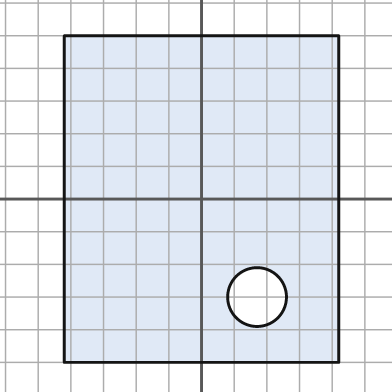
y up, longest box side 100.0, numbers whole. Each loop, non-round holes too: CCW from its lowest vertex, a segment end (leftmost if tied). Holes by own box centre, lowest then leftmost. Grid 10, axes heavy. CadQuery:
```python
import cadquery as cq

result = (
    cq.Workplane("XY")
    .moveTo(-42.0, -50.0)
    .lineTo(42.0, -50.0)
    .lineTo(42.0, 50.0)
    .lineTo(-42.0, 50.0)
    .close()
    .moveTo(17.0, -30.0)
    .circle(9.0)
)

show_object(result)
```